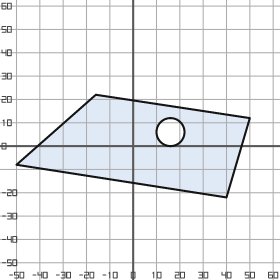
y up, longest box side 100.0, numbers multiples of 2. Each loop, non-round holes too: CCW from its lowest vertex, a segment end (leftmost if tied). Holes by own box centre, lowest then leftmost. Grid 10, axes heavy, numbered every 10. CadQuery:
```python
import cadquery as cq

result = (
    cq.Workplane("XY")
    .moveTo(40.0, -22.0)
    .lineTo(50.0, 12.0)
    .lineTo(-16.0, 22.0)
    .lineTo(-50.0, -8.0)
    .close()
    .moveTo(16.0, 6.0)
    .circle(6.0)
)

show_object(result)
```